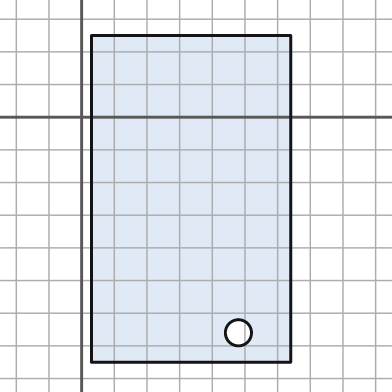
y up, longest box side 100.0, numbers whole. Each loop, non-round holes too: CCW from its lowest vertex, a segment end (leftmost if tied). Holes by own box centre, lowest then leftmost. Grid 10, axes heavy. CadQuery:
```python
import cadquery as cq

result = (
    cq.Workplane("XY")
    .moveTo(3.0, -75.0)
    .lineTo(64.0, -75.0)
    .lineTo(64.0, 25.0)
    .lineTo(3.0, 25.0)
    .close()
    .moveTo(48.0, -66.0)
    .circle(4.0)
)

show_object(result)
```